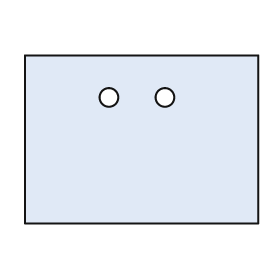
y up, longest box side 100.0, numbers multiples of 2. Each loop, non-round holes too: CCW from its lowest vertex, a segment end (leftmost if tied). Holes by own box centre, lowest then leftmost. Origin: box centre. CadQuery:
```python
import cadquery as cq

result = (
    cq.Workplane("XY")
    .moveTo(-50.0, -36.0)
    .lineTo(50.0, -36.0)
    .lineTo(50.0, 36.0)
    .lineTo(-50.0, 36.0)
    .close()
    .moveTo(-14.0, 18.0)
    .circle(4.0)
    .moveTo(10.0, 18.0)
    .circle(4.0)
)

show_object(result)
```